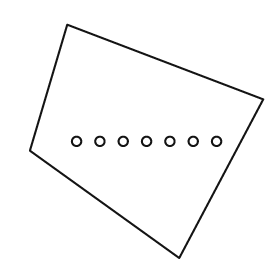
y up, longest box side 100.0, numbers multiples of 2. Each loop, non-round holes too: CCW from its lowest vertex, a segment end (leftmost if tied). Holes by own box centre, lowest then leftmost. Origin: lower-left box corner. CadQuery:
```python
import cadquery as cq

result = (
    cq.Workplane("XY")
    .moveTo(64.0, 0.0)
    .lineTo(100.0, 68.0)
    .lineTo(16.0, 100.0)
    .lineTo(0.0, 46.0)
    .close()
    .moveTo(20.0, 50.0)
    .circle(2.0)
    .moveTo(30.0, 50.0)
    .circle(2.0)
    .moveTo(40.0, 50.0)
    .circle(2.0)
    .moveTo(50.0, 50.0)
    .circle(2.0)
    .moveTo(60.0, 50.0)
    .circle(2.0)
    .moveTo(70.0, 50.0)
    .circle(2.0)
    .moveTo(80.0, 50.0)
    .circle(2.0)
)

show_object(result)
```